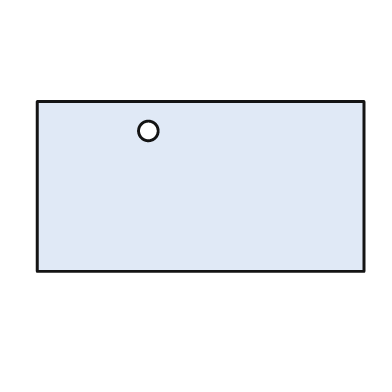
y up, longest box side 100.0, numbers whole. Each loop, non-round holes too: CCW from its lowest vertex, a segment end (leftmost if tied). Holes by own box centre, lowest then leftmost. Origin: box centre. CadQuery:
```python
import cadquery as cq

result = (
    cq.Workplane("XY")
    .moveTo(-50.0, -26.0)
    .lineTo(50.0, -26.0)
    .lineTo(50.0, 26.0)
    .lineTo(-50.0, 26.0)
    .close()
    .moveTo(-16.0, 17.0)
    .circle(3.0)
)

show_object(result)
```